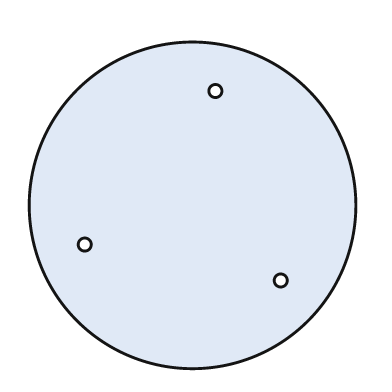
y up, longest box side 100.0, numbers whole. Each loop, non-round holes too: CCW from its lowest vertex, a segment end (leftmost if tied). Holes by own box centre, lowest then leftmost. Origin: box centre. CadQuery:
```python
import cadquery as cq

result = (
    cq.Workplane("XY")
    .moveTo(0.0, 0.0)
    .circle(50.0)
    .moveTo(27.0, -23.0)
    .circle(2.0)
    .moveTo(-33.0, -12.0)
    .circle(2.0)
    .moveTo(7.0, 35.0)
    .circle(2.0)
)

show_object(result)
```